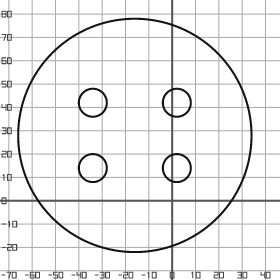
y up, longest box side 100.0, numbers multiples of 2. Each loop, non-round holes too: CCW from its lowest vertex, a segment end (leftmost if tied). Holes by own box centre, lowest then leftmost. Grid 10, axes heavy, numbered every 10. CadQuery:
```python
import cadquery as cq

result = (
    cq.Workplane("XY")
    .moveTo(-16.0, 28.0)
    .circle(50.0)
    .moveTo(-34.0, 14.0)
    .circle(6.0)
    .moveTo(2.0, 14.0)
    .circle(6.0)
    .moveTo(-34.0, 42.0)
    .circle(6.0)
    .moveTo(2.0, 42.0)
    .circle(6.0)
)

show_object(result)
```